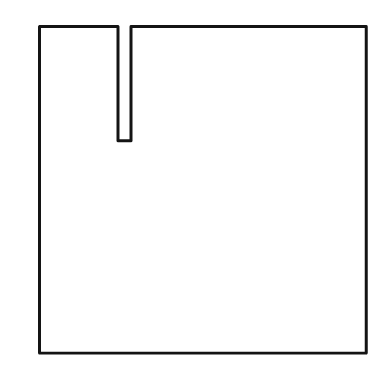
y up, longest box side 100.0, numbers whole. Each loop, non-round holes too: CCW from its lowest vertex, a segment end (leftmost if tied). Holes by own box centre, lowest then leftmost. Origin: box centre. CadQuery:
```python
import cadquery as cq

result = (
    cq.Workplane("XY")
    .moveTo(-50.0, -50.0)
    .lineTo(50.0, -50.0)
    .lineTo(50.0, 50.0)
    .lineTo(-22.0, 50.0)
    .lineTo(-22.0, 15.0)
    .lineTo(-26.0, 15.0)
    .lineTo(-26.0, 50.0)
    .lineTo(-50.0, 50.0)
    .close()
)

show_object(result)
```